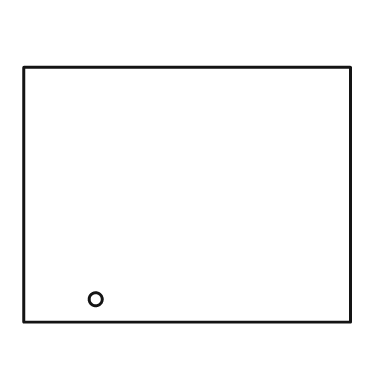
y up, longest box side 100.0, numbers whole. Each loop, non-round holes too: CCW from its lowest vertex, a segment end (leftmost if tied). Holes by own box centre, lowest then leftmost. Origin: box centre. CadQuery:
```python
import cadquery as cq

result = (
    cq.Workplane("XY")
    .moveTo(-50.0, -39.0)
    .lineTo(50.0, -39.0)
    .lineTo(50.0, 39.0)
    .lineTo(-50.0, 39.0)
    .close()
    .moveTo(-28.0, -32.0)
    .circle(2.0)
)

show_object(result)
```